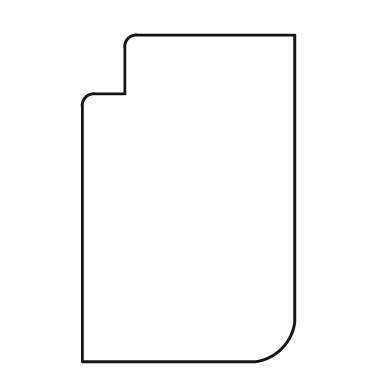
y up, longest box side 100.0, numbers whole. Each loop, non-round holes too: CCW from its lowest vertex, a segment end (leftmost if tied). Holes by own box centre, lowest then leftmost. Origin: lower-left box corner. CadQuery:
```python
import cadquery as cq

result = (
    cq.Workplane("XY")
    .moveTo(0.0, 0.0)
    .lineTo(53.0, 0.0)
    .threePointArc((61.0, 4.0), (65.0, 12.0))
    .lineTo(65.0, 100.0)
    .lineTo(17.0, 100.0)
    .threePointArc((14.0, 99.0), (13.0, 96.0))
    .lineTo(13.0, 82.0)
    .lineTo(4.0, 82.0)
    .threePointArc((1.0, 81.0), (0.0, 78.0))
    .close()
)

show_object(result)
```